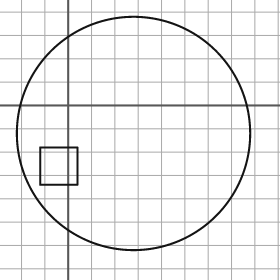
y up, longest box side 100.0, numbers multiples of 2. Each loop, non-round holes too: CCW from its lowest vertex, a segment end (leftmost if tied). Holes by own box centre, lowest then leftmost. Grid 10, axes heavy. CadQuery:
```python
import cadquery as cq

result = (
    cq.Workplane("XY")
    .moveTo(28.0, -12.0)
    .circle(50.0)
    .moveTo(-12.0, -34.0)
    .lineTo(4.0, -34.0)
    .lineTo(4.0, -18.0)
    .lineTo(-12.0, -18.0)
    .close()
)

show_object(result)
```